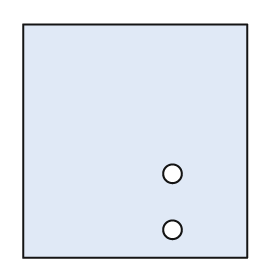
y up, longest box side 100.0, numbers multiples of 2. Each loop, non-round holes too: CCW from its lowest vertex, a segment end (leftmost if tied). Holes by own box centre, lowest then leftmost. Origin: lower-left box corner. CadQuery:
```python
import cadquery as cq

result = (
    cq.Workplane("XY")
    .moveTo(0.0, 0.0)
    .lineTo(96.0, 0.0)
    .lineTo(96.0, 100.0)
    .lineTo(0.0, 100.0)
    .close()
    .moveTo(64.0, 12.0)
    .circle(4.0)
    .moveTo(64.0, 36.0)
    .circle(4.0)
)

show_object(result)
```